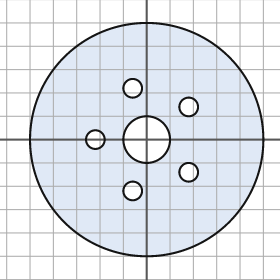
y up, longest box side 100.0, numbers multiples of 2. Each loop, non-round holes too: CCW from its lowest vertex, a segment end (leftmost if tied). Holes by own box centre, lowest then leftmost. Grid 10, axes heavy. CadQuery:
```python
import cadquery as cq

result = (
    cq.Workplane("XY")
    .moveTo(0.0, 0.0)
    .circle(50.0)
    .moveTo(-6.0, -22.0)
    .circle(4.0)
    .moveTo(18.0, -14.0)
    .circle(4.0)
    .moveTo(-22.0, 0.0)
    .circle(4.0)
    .moveTo(0.0, 0.0)
    .circle(10.0)
    .moveTo(18.0, 14.0)
    .circle(4.0)
    .moveTo(-6.0, 22.0)
    .circle(4.0)
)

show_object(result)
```